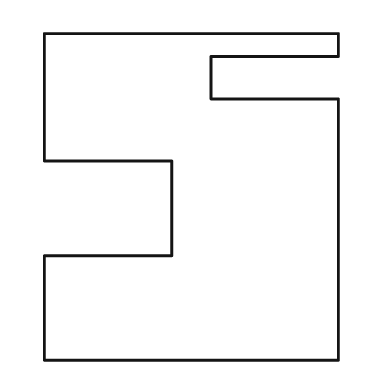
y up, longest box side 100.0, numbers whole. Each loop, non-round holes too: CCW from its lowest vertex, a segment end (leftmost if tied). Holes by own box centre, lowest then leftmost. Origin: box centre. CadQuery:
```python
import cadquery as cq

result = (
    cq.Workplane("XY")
    .moveTo(-45.0, -50.0)
    .lineTo(45.0, -50.0)
    .lineTo(45.0, 30.0)
    .lineTo(6.0, 30.0)
    .lineTo(6.0, 43.0)
    .lineTo(45.0, 43.0)
    .lineTo(45.0, 50.0)
    .lineTo(-45.0, 50.0)
    .lineTo(-45.0, 11.0)
    .lineTo(-6.0, 11.0)
    .lineTo(-6.0, -18.0)
    .lineTo(-45.0, -18.0)
    .close()
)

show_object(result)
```